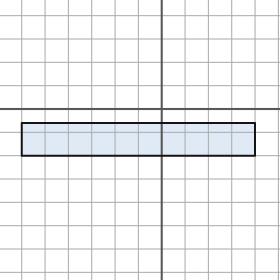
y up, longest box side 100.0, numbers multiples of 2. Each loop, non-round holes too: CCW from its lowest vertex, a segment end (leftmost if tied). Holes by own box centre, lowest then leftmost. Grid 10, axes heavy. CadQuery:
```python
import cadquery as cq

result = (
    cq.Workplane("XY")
    .moveTo(-60.0, -20.0)
    .lineTo(40.0, -20.0)
    .lineTo(40.0, -6.0)
    .lineTo(-60.0, -6.0)
    .close()
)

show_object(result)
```